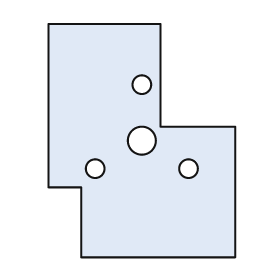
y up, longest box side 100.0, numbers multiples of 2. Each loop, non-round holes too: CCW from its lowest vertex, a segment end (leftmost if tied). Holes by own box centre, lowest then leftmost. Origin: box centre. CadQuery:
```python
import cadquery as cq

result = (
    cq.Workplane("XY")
    .moveTo(-26.0, -50.0)
    .lineTo(40.0, -50.0)
    .lineTo(40.0, 6.0)
    .lineTo(8.0, 6.0)
    .lineTo(8.0, 50.0)
    .lineTo(-40.0, 50.0)
    .lineTo(-40.0, -20.0)
    .lineTo(-26.0, -20.0)
    .close()
    .moveTo(-20.0, -12.0)
    .circle(4.0)
    .moveTo(20.0, -12.0)
    .circle(4.0)
    .moveTo(0.0, 0.0)
    .circle(6.0)
    .moveTo(0.0, 24.0)
    .circle(4.0)
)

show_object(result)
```